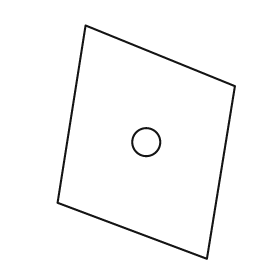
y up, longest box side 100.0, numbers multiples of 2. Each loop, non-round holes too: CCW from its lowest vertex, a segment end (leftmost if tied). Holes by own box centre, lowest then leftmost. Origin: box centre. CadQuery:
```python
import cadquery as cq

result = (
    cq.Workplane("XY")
    .moveTo(26.0, -50.0)
    .lineTo(38.0, 24.0)
    .lineTo(-26.0, 50.0)
    .lineTo(-38.0, -26.0)
    .close()
    .moveTo(0.0, 0.0)
    .circle(6.0)
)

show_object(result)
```